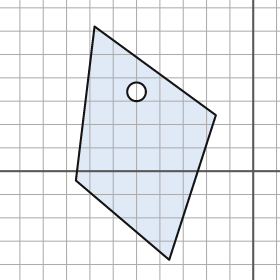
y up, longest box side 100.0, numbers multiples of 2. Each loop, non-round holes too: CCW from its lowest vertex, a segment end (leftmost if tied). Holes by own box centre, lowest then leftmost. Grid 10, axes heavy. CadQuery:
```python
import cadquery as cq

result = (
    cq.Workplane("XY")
    .moveTo(-36.0, -38.0)
    .lineTo(-16.0, 24.0)
    .lineTo(-68.0, 62.0)
    .lineTo(-76.0, -4.0)
    .close()
    .moveTo(-50.0, 34.0)
    .circle(4.0)
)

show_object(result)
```